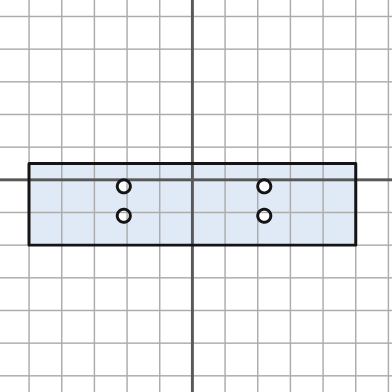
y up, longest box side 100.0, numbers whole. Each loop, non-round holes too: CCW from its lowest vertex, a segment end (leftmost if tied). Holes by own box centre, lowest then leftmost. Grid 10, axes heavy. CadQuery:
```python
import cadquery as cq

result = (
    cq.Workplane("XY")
    .moveTo(-50.0, -20.0)
    .lineTo(50.0, -20.0)
    .lineTo(50.0, 5.0)
    .lineTo(-50.0, 5.0)
    .close()
    .moveTo(-21.0, -11.0)
    .circle(2.0)
    .moveTo(22.0, -11.0)
    .circle(2.0)
    .moveTo(-21.0, -2.0)
    .circle(2.0)
    .moveTo(22.0, -2.0)
    .circle(2.0)
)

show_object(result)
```